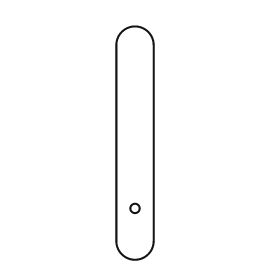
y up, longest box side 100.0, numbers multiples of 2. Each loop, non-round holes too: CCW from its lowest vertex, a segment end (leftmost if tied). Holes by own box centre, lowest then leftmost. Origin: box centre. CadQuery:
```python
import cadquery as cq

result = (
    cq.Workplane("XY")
    .moveTo(-8.0, -42.0)
    .threePointArc((0.0, -50.0), (8.0, -42.0))
    .lineTo(8.0, 42.0)
    .threePointArc((0.0, 50.0), (-8.0, 42.0))
    .close()
    .moveTo(0.0, -28.0)
    .circle(2.0)
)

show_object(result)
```